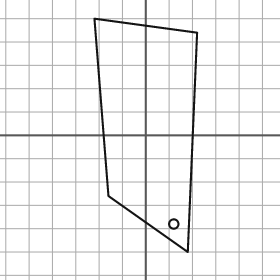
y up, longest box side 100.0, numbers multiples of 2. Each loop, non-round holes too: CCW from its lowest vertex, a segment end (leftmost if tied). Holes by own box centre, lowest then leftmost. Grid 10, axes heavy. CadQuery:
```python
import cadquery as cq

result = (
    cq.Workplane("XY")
    .moveTo(18.0, -50.0)
    .lineTo(22.0, 44.0)
    .lineTo(-22.0, 50.0)
    .lineTo(-16.0, -26.0)
    .close()
    .moveTo(12.0, -38.0)
    .circle(2.0)
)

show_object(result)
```